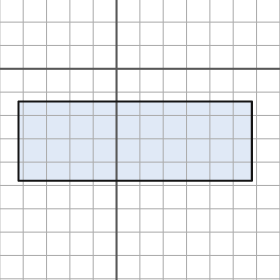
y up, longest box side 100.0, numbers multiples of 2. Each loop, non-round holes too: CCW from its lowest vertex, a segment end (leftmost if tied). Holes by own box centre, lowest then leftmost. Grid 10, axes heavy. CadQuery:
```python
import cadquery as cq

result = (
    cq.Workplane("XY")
    .moveTo(-42.0, -48.0)
    .lineTo(58.0, -48.0)
    .lineTo(58.0, -14.0)
    .lineTo(-42.0, -14.0)
    .close()
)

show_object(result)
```